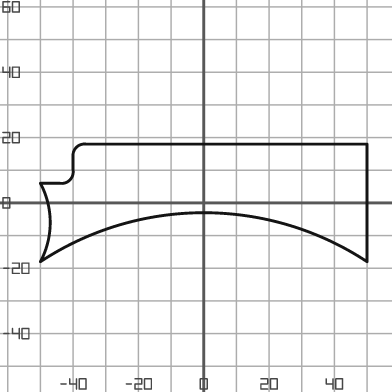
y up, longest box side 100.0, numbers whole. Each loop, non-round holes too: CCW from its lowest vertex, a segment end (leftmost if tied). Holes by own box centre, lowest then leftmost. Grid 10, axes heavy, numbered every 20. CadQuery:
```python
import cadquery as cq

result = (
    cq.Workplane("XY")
    .moveTo(-50.0, -18.0)
    .threePointArc((0.0, -3.0), (50.0, -18.0))
    .lineTo(50.0, 18.0)
    .lineTo(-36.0, 18.0)
    .threePointArc((-39.0, 17.0), (-40.0, 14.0))
    .lineTo(-40.0, 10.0)
    .threePointArc((-41.0, 7.0), (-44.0, 6.0))
    .lineTo(-50.0, 6.0)
    .threePointArc((-47.0, -6.0), (-50.0, -18.0))
    .close()
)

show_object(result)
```